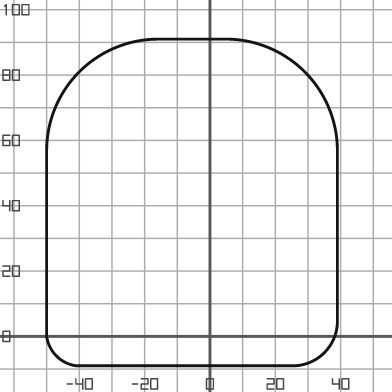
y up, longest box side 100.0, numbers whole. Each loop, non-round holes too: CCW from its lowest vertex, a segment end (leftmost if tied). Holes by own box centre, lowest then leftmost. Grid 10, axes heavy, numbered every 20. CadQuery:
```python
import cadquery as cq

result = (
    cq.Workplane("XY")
    .moveTo(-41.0, -9.0)
    .lineTo(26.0, -9.0)
    .threePointArc((35.0, -5.0), (39.0, 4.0))
    .lineTo(39.0, 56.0)
    .threePointArc((29.0, 81.0), (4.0, 91.0))
    .lineTo(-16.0, 91.0)
    .threePointArc((-40.0, 81.0), (-50.0, 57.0))
    .lineTo(-50.0, 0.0)
    .threePointArc((-47.0, -6.0), (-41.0, -9.0))
    .close()
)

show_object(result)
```